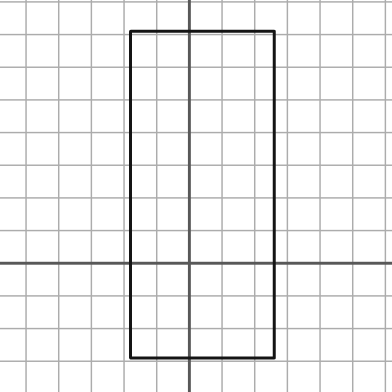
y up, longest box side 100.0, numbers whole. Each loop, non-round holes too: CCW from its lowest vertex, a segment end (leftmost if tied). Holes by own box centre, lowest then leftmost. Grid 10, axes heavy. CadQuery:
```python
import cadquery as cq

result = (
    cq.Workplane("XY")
    .moveTo(-18.0, -29.0)
    .lineTo(26.0, -29.0)
    .lineTo(26.0, 71.0)
    .lineTo(-18.0, 71.0)
    .close()
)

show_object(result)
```